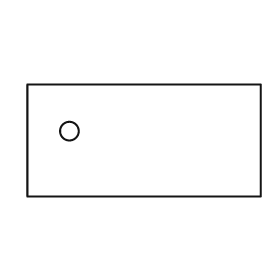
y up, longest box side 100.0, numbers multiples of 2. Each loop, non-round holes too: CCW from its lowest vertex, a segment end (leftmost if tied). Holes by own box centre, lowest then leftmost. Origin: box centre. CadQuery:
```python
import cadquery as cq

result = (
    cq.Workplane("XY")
    .moveTo(-50.0, -24.0)
    .lineTo(50.0, -24.0)
    .lineTo(50.0, 24.0)
    .lineTo(-50.0, 24.0)
    .close()
    .moveTo(-32.0, 4.0)
    .circle(4.0)
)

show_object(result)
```